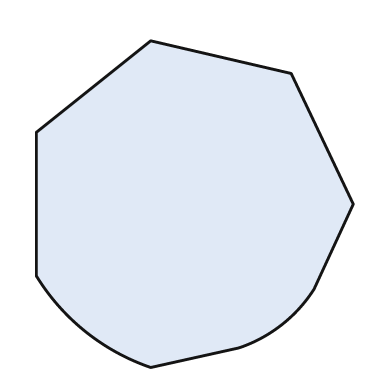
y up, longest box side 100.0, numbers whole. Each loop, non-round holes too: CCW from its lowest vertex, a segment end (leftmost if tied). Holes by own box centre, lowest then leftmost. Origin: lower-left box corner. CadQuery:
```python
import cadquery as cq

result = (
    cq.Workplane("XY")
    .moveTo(35.0, 0.0)
    .lineTo(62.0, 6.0)
    .threePointArc((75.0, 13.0), (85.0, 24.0))
    .lineTo(97.0, 50.0)
    .lineTo(78.0, 90.0)
    .lineTo(35.0, 100.0)
    .lineTo(0.0, 72.0)
    .lineTo(0.0, 28.0)
    .threePointArc((15.0, 11.0), (35.0, 0.0))
    .close()
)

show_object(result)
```